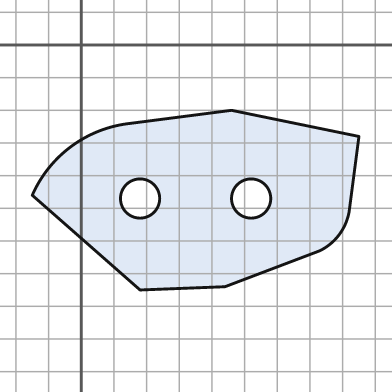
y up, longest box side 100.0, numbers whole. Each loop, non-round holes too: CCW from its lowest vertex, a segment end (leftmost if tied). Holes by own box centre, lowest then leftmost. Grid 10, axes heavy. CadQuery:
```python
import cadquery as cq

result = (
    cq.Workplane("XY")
    .moveTo(18.0, -75.0)
    .lineTo(44.0, -74.0)
    .lineTo(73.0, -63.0)
    .threePointArc((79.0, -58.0), (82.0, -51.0))
    .lineTo(85.0, -28.0)
    .lineTo(46.0, -20.0)
    .lineTo(15.0, -24.0)
    .threePointArc((-3.0, -31.0), (-15.0, -46.0))
    .close()
    .moveTo(18.0, -47.0)
    .circle(6.0)
    .moveTo(52.0, -47.0)
    .circle(6.0)
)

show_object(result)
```